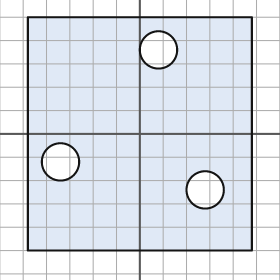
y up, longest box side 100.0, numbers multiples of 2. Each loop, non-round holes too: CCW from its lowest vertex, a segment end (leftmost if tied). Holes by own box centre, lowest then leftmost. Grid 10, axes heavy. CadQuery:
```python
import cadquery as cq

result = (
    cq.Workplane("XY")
    .moveTo(-48.0, -50.0)
    .lineTo(48.0, -50.0)
    .lineTo(48.0, 50.0)
    .lineTo(-48.0, 50.0)
    .close()
    .moveTo(28.0, -24.0)
    .circle(8.0)
    .moveTo(-34.0, -12.0)
    .circle(8.0)
    .moveTo(8.0, 36.0)
    .circle(8.0)
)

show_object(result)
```